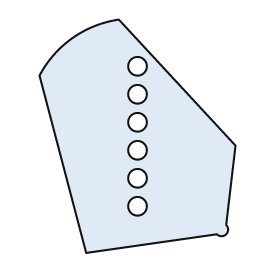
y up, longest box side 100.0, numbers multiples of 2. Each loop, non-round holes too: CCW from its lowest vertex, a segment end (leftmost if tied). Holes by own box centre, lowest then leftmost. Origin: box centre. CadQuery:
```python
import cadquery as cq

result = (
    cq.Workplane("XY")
    .moveTo(-22.0, -50.0)
    .lineTo(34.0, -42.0)
    .threePointArc((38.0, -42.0), (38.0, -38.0))
    .lineTo(42.0, -4.0)
    .lineTo(-8.0, 50.0)
    .threePointArc((-28.0, 42.0), (-42.0, 26.0))
    .close()
    .moveTo(0.0, -30.0)
    .circle(4.0)
    .moveTo(0.0, -18.0)
    .circle(4.0)
    .moveTo(0.0, -6.0)
    .circle(4.0)
    .moveTo(0.0, 6.0)
    .circle(4.0)
    .moveTo(0.0, 18.0)
    .circle(4.0)
    .moveTo(0.0, 30.0)
    .circle(4.0)
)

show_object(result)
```